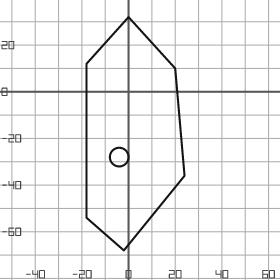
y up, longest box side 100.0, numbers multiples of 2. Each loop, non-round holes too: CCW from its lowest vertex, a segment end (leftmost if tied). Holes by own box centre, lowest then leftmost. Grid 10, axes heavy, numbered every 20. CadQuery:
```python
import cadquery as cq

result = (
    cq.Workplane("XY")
    .moveTo(-2.0, -68.0)
    .lineTo(24.0, -36.0)
    .lineTo(20.0, 10.0)
    .lineTo(0.0, 32.0)
    .lineTo(-18.0, 12.0)
    .lineTo(-18.0, -54.0)
    .close()
    .moveTo(-4.0, -28.0)
    .circle(4.0)
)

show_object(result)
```